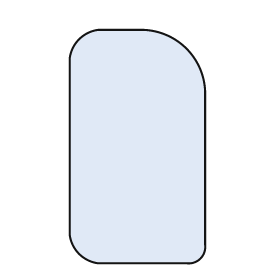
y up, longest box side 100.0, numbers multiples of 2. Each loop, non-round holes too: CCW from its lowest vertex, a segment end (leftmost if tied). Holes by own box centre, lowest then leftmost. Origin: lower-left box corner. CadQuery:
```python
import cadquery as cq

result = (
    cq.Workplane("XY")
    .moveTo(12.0, 0.0)
    .lineTo(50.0, 0.0)
    .threePointArc((56.0, 2.0), (58.0, 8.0))
    .lineTo(58.0, 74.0)
    .threePointArc((50.0, 92.0), (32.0, 100.0))
    .lineTo(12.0, 100.0)
    .threePointArc((4.0, 96.0), (0.0, 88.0))
    .lineTo(0.0, 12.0)
    .threePointArc((4.0, 4.0), (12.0, 0.0))
    .close()
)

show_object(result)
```